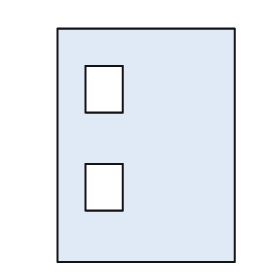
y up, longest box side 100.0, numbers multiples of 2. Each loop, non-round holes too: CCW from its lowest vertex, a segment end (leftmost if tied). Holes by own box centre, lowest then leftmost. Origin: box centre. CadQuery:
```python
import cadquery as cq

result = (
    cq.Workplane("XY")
    .moveTo(-38.0, -50.0)
    .lineTo(38.0, -50.0)
    .lineTo(38.0, 50.0)
    .lineTo(-38.0, 50.0)
    .close()
    .moveTo(-26.0, -28.0)
    .lineTo(-10.0, -28.0)
    .lineTo(-10.0, -8.0)
    .lineTo(-26.0, -8.0)
    .close()
    .moveTo(-26.0, 14.0)
    .lineTo(-10.0, 14.0)
    .lineTo(-10.0, 34.0)
    .lineTo(-26.0, 34.0)
    .close()
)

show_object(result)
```